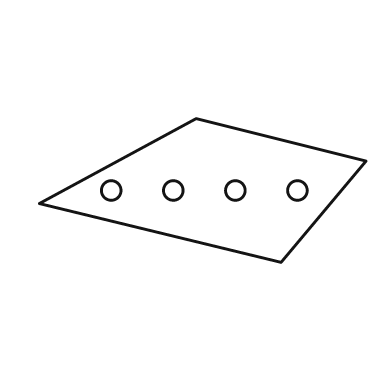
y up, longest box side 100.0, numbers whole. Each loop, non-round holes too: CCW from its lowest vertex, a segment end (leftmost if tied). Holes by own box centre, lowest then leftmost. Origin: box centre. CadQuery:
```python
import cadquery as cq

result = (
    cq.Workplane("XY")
    .moveTo(24.0, -22.0)
    .lineTo(50.0, 9.0)
    .lineTo(-2.0, 22.0)
    .lineTo(-50.0, -4.0)
    .close()
    .moveTo(-28.0, 0.0)
    .circle(3.0)
    .moveTo(-9.0, 0.0)
    .circle(3.0)
    .moveTo(10.0, 0.0)
    .circle(3.0)
    .moveTo(29.0, 0.0)
    .circle(3.0)
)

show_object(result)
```